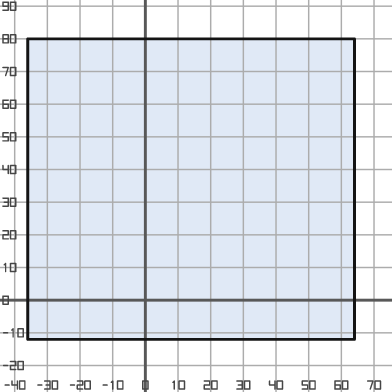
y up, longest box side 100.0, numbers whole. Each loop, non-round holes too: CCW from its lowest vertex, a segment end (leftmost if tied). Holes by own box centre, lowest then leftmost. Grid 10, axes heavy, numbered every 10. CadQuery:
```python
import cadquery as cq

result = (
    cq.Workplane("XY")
    .moveTo(-36.0, -12.0)
    .lineTo(64.0, -12.0)
    .lineTo(64.0, 80.0)
    .lineTo(-36.0, 80.0)
    .close()
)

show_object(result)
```